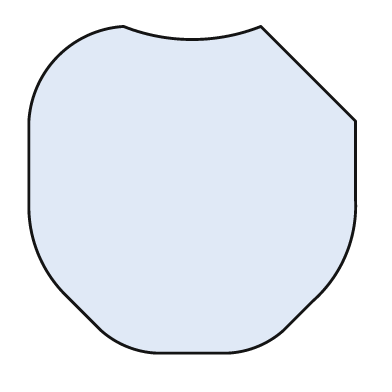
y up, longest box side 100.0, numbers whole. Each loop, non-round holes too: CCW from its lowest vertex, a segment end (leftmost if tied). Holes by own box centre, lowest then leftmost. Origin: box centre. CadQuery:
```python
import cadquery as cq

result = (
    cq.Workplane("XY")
    .moveTo(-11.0, -50.0)
    .lineTo(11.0, -50.0)
    .threePointArc((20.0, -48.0), (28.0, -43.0))
    .lineTo(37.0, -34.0)
    .threePointArc((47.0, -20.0), (50.0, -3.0))
    .lineTo(50.0, 21.0)
    .lineTo(21.0, 50.0)
    .threePointArc((0.0, 46.0), (-21.0, 50.0))
    .threePointArc((-41.0, 41.0), (-50.0, 21.0))
    .lineTo(-50.0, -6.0)
    .threePointArc((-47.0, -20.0), (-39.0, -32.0))
    .lineTo(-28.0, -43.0)
    .threePointArc((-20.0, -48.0), (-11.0, -50.0))
    .close()
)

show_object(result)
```